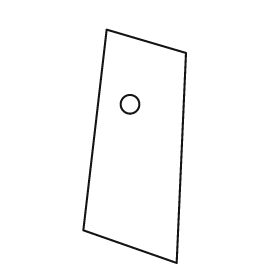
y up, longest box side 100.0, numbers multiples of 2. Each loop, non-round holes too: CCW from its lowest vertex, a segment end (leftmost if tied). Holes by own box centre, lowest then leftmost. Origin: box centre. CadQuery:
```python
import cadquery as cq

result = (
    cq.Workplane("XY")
    .moveTo(18.0, -50.0)
    .lineTo(22.0, 40.0)
    .lineTo(-12.0, 50.0)
    .lineTo(-22.0, -36.0)
    .close()
    .moveTo(-2.0, 18.0)
    .circle(4.0)
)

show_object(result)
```